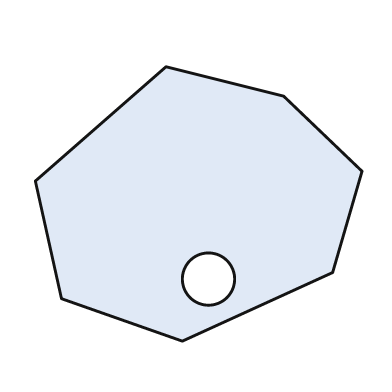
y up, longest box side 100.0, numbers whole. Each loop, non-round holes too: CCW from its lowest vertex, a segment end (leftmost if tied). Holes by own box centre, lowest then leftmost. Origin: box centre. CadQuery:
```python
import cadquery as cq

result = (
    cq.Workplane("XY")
    .moveTo(-5.0, -42.0)
    .lineTo(41.0, -21.0)
    .lineTo(50.0, 10.0)
    .lineTo(26.0, 33.0)
    .lineTo(-10.0, 42.0)
    .lineTo(-50.0, 7.0)
    .lineTo(-42.0, -29.0)
    .close()
    .moveTo(3.0, -23.0)
    .circle(8.0)
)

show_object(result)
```